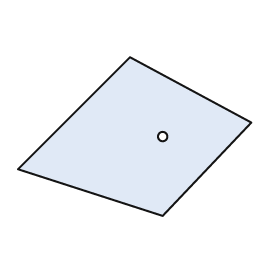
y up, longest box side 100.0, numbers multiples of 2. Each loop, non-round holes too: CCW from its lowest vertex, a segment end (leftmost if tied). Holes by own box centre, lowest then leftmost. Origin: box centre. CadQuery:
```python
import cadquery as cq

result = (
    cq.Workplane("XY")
    .moveTo(12.0, -34.0)
    .lineTo(50.0, 6.0)
    .lineTo(-2.0, 34.0)
    .lineTo(-50.0, -14.0)
    .close()
    .moveTo(12.0, 0.0)
    .circle(2.0)
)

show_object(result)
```